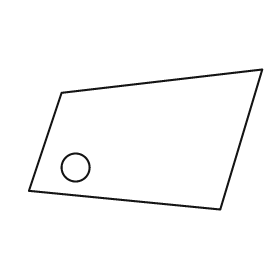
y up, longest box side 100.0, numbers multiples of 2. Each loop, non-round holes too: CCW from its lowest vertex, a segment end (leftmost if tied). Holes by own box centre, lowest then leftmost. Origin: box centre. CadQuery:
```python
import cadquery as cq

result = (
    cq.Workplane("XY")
    .moveTo(32.0, -30.0)
    .lineTo(50.0, 30.0)
    .lineTo(-36.0, 20.0)
    .lineTo(-50.0, -22.0)
    .close()
    .moveTo(-30.0, -12.0)
    .circle(6.0)
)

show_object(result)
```